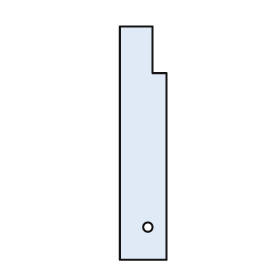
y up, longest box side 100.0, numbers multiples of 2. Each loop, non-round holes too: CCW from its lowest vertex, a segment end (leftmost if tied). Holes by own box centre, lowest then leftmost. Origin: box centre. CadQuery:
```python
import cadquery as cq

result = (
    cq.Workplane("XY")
    .moveTo(-10.0, -50.0)
    .lineTo(10.0, -50.0)
    .lineTo(10.0, 30.0)
    .lineTo(4.0, 30.0)
    .lineTo(4.0, 50.0)
    .lineTo(-10.0, 50.0)
    .close()
    .moveTo(2.0, -36.0)
    .circle(2.0)
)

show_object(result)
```